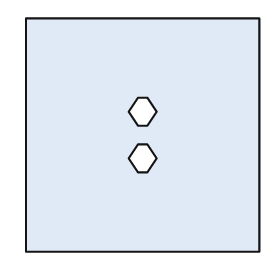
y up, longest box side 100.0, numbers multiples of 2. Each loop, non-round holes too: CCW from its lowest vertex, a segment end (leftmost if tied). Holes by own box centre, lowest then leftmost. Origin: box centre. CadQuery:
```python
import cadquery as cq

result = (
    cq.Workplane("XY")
    .moveTo(-50.0, -50.0)
    .lineTo(50.0, -50.0)
    .lineTo(50.0, 50.0)
    .lineTo(-50.0, 50.0)
    .close()
    .moveTo(-2.0, -16.0)
    .lineTo(2.0, -16.0)
    .lineTo(6.0, -10.0)
    .lineTo(2.0, -4.0)
    .lineTo(-2.0, -4.0)
    .lineTo(-6.0, -10.0)
    .close()
    .moveTo(-2.0, 4.0)
    .lineTo(2.0, 4.0)
    .lineTo(6.0, 10.0)
    .lineTo(2.0, 16.0)
    .lineTo(-2.0, 16.0)
    .lineTo(-6.0, 10.0)
    .close()
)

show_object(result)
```